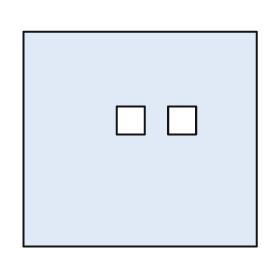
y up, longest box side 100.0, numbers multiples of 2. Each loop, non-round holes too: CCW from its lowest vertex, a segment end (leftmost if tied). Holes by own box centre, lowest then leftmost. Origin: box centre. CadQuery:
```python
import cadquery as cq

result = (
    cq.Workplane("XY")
    .moveTo(-50.0, -46.0)
    .lineTo(50.0, -46.0)
    .lineTo(50.0, 46.0)
    .lineTo(-50.0, 46.0)
    .close()
    .moveTo(-10.0, 2.0)
    .lineTo(2.0, 2.0)
    .lineTo(2.0, 14.0)
    .lineTo(-10.0, 14.0)
    .close()
    .moveTo(12.0, 2.0)
    .lineTo(24.0, 2.0)
    .lineTo(24.0, 14.0)
    .lineTo(12.0, 14.0)
    .close()
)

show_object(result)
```